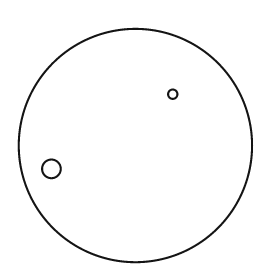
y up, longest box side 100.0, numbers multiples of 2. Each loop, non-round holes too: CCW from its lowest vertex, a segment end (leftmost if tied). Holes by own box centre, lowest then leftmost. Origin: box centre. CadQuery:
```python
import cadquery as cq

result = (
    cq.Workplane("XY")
    .moveTo(0.0, 0.0)
    .circle(50.0)
    .moveTo(-36.0, -10.0)
    .circle(4.0)
    .moveTo(16.0, 22.0)
    .circle(2.0)
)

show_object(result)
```